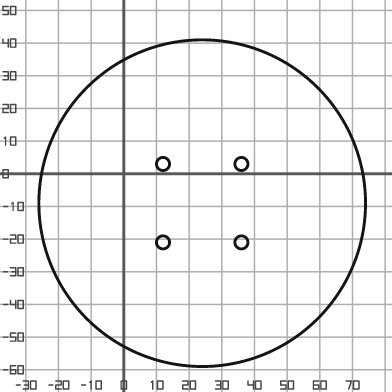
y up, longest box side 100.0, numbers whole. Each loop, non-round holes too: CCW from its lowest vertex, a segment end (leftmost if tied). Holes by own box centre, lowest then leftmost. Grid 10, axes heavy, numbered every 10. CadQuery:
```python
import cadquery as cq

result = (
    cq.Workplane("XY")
    .moveTo(24.0, -9.0)
    .circle(50.0)
    .moveTo(12.0, -21.0)
    .circle(2.0)
    .moveTo(36.0, -21.0)
    .circle(2.0)
    .moveTo(12.0, 3.0)
    .circle(2.0)
    .moveTo(36.0, 3.0)
    .circle(2.0)
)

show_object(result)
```